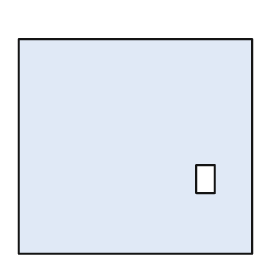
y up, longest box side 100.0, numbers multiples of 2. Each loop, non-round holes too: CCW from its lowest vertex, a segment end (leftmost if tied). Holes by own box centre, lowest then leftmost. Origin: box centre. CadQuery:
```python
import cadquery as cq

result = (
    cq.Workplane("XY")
    .moveTo(-50.0, -46.0)
    .lineTo(50.0, -46.0)
    .lineTo(50.0, 46.0)
    .lineTo(-50.0, 46.0)
    .close()
    .moveTo(26.0, -20.0)
    .lineTo(34.0, -20.0)
    .lineTo(34.0, -8.0)
    .lineTo(26.0, -8.0)
    .close()
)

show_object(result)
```